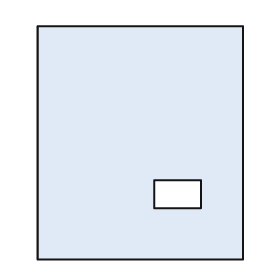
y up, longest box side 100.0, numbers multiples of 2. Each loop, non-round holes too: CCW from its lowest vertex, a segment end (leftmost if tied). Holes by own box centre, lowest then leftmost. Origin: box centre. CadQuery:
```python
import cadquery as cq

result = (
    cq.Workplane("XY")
    .moveTo(-44.0, -50.0)
    .lineTo(44.0, -50.0)
    .lineTo(44.0, 50.0)
    .lineTo(-44.0, 50.0)
    .close()
    .moveTo(6.0, -28.0)
    .lineTo(26.0, -28.0)
    .lineTo(26.0, -16.0)
    .lineTo(6.0, -16.0)
    .close()
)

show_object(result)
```